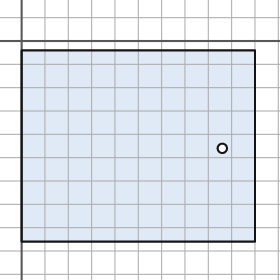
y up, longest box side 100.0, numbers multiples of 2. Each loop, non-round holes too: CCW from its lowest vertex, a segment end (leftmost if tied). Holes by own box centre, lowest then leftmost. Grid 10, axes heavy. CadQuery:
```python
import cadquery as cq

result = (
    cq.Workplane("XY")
    .moveTo(0.0, -86.0)
    .lineTo(100.0, -86.0)
    .lineTo(100.0, -4.0)
    .lineTo(0.0, -4.0)
    .close()
    .moveTo(86.0, -46.0)
    .circle(2.0)
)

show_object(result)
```